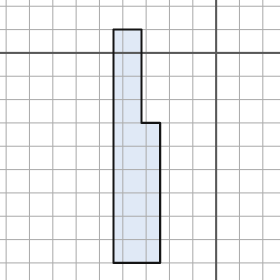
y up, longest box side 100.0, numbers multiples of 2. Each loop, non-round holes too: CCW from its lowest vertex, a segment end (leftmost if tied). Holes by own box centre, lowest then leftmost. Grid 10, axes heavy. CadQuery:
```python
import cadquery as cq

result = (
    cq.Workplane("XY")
    .moveTo(-44.0, -90.0)
    .lineTo(-24.0, -90.0)
    .lineTo(-24.0, -30.0)
    .lineTo(-32.0, -30.0)
    .lineTo(-32.0, 10.0)
    .lineTo(-44.0, 10.0)
    .close()
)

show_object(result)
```